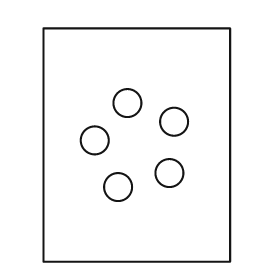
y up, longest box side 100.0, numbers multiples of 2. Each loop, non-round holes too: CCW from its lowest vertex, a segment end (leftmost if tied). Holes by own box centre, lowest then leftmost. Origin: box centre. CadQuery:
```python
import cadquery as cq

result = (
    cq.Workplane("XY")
    .moveTo(-40.0, -50.0)
    .lineTo(40.0, -50.0)
    .lineTo(40.0, 50.0)
    .lineTo(-40.0, 50.0)
    .close()
    .moveTo(-8.0, -18.0)
    .circle(6.0)
    .moveTo(14.0, -12.0)
    .circle(6.0)
    .moveTo(-18.0, 2.0)
    .circle(6.0)
    .moveTo(16.0, 10.0)
    .circle(6.0)
    .moveTo(-4.0, 18.0)
    .circle(6.0)
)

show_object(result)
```